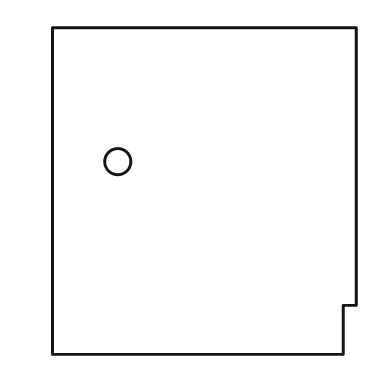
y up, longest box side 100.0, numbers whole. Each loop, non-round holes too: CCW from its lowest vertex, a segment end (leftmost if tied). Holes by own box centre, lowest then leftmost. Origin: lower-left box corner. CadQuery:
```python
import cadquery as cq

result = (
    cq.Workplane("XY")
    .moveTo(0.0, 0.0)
    .lineTo(89.0, 0.0)
    .lineTo(89.0, 15.0)
    .lineTo(93.0, 15.0)
    .lineTo(93.0, 100.0)
    .lineTo(0.0, 100.0)
    .close()
    .moveTo(20.0, 59.0)
    .circle(4.0)
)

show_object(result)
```